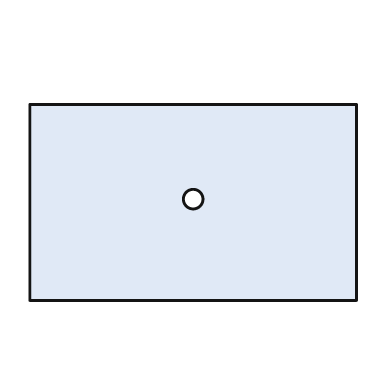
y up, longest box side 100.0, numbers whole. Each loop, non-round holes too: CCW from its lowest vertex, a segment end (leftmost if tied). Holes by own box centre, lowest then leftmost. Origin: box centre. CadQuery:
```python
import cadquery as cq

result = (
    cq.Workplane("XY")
    .moveTo(-50.0, -30.0)
    .lineTo(50.0, -30.0)
    .lineTo(50.0, 30.0)
    .lineTo(-50.0, 30.0)
    .close()
    .moveTo(0.0, 1.0)
    .circle(3.0)
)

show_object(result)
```